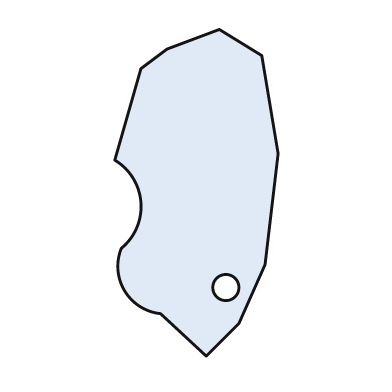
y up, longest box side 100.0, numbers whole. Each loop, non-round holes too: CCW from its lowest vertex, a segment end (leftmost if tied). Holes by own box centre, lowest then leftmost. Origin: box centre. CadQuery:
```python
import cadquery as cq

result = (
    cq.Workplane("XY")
    .moveTo(3.0, -50.0)
    .lineTo(13.0, -40.0)
    .lineTo(21.0, -22.0)
    .lineTo(25.0, 12.0)
    .lineTo(20.0, 42.0)
    .lineTo(7.0, 50.0)
    .lineTo(-9.0, 44.0)
    .lineTo(-17.0, 38.0)
    .lineTo(-25.0, 10.0)
    .threePointArc((-17.0, -3.0), (-23.0, -17.0))
    .threePointArc((-22.0, -30.0), (-11.0, -37.0))
    .close()
    .moveTo(9.0, -29.0)
    .circle(4.0)
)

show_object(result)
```